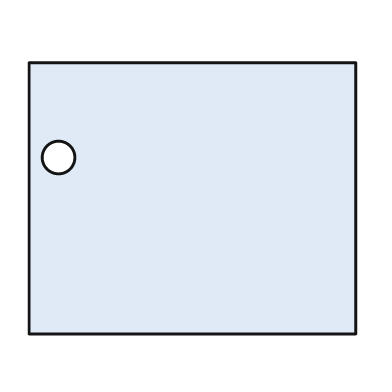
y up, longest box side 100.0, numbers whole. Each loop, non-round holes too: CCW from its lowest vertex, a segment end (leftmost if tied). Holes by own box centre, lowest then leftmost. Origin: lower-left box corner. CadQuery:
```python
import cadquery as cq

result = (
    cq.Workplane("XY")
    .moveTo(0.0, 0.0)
    .lineTo(100.0, 0.0)
    .lineTo(100.0, 83.0)
    .lineTo(0.0, 83.0)
    .close()
    .moveTo(9.0, 54.0)
    .circle(5.0)
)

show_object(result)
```